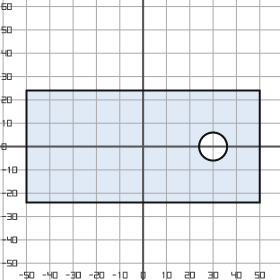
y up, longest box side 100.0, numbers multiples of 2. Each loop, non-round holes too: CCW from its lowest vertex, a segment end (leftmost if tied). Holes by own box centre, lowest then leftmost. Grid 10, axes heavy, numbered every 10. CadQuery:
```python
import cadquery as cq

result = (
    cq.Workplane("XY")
    .moveTo(-50.0, -24.0)
    .lineTo(50.0, -24.0)
    .lineTo(50.0, 24.0)
    .lineTo(-50.0, 24.0)
    .close()
    .moveTo(30.0, 0.0)
    .circle(6.0)
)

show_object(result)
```